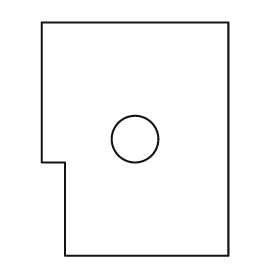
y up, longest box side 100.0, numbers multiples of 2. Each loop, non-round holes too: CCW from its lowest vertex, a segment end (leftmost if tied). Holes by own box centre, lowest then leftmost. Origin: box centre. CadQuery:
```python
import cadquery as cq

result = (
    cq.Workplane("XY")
    .moveTo(-30.0, -50.0)
    .lineTo(40.0, -50.0)
    .lineTo(40.0, 50.0)
    .lineTo(-40.0, 50.0)
    .lineTo(-40.0, -10.0)
    .lineTo(-30.0, -10.0)
    .close()
    .moveTo(0.0, 0.0)
    .circle(10.0)
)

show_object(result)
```